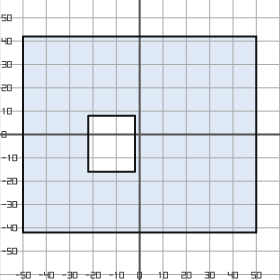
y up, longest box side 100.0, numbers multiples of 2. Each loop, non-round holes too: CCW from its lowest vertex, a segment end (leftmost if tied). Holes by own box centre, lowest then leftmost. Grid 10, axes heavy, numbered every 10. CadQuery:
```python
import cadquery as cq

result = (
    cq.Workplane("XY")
    .moveTo(-50.0, -42.0)
    .lineTo(50.0, -42.0)
    .lineTo(50.0, 42.0)
    .lineTo(-50.0, 42.0)
    .close()
    .moveTo(-22.0, -16.0)
    .lineTo(-2.0, -16.0)
    .lineTo(-2.0, 8.0)
    .lineTo(-22.0, 8.0)
    .close()
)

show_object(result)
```